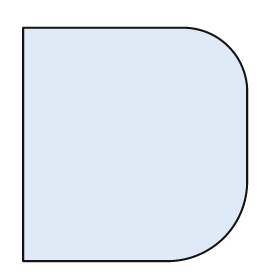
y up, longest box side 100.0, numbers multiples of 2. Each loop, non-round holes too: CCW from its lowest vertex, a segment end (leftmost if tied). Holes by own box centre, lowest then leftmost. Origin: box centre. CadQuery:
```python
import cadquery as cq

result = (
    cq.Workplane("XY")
    .moveTo(-48.0, -50.0)
    .lineTo(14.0, -50.0)
    .threePointArc((38.0, -40.0), (48.0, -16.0))
    .lineTo(48.0, 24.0)
    .threePointArc((40.0, 42.0), (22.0, 50.0))
    .lineTo(-48.0, 50.0)
    .close()
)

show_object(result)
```